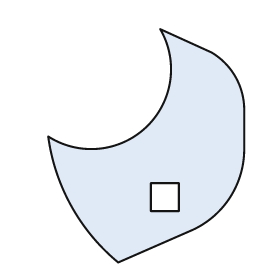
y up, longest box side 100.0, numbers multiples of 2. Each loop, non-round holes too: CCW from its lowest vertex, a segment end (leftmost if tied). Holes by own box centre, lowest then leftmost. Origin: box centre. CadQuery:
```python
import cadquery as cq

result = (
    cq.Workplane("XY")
    .moveTo(-12.0, -50.0)
    .lineTo(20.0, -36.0)
    .threePointArc((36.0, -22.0), (42.0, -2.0))
    .lineTo(42.0, 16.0)
    .threePointArc((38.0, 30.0), (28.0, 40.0))
    .lineTo(6.0, 50.0)
    .threePointArc((0.0, 8.0), (-42.0, 4.0))
    .threePointArc((-32.0, -26.0), (-12.0, -50.0))
    .close()
    .moveTo(2.0, -28.0)
    .lineTo(14.0, -28.0)
    .lineTo(14.0, -16.0)
    .lineTo(2.0, -16.0)
    .close()
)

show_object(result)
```